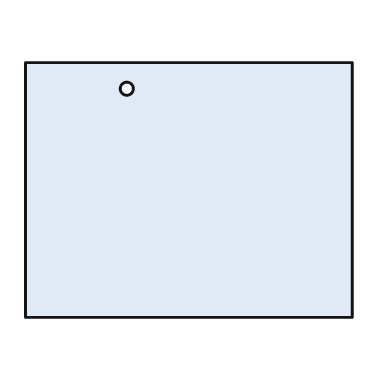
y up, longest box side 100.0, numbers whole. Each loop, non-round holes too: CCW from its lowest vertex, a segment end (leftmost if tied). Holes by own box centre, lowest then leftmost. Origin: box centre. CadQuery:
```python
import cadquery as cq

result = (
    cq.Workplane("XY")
    .moveTo(-50.0, -39.0)
    .lineTo(50.0, -39.0)
    .lineTo(50.0, 39.0)
    .lineTo(-50.0, 39.0)
    .close()
    .moveTo(-19.0, 31.0)
    .circle(2.0)
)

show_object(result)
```